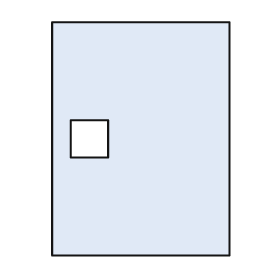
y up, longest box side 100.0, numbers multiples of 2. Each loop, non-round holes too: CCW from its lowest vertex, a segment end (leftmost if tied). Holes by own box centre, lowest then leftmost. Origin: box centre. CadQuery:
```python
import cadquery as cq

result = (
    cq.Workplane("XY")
    .moveTo(-38.0, -50.0)
    .lineTo(38.0, -50.0)
    .lineTo(38.0, 50.0)
    .lineTo(-38.0, 50.0)
    .close()
    .moveTo(-30.0, -8.0)
    .lineTo(-14.0, -8.0)
    .lineTo(-14.0, 8.0)
    .lineTo(-30.0, 8.0)
    .close()
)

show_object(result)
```